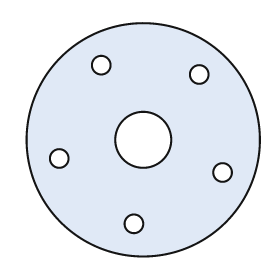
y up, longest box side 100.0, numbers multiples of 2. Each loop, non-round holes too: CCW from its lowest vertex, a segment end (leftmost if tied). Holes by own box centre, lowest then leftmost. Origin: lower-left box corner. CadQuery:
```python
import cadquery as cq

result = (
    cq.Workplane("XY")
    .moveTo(50.0, 50.0)
    .circle(50.0)
    .moveTo(46.0, 14.0)
    .circle(4.0)
    .moveTo(84.0, 36.0)
    .circle(4.0)
    .moveTo(14.0, 42.0)
    .circle(4.0)
    .moveTo(50.0, 50.0)
    .circle(12.0)
    .moveTo(74.0, 78.0)
    .circle(4.0)
    .moveTo(32.0, 82.0)
    .circle(4.0)
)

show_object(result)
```